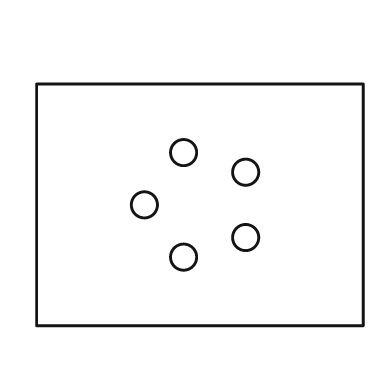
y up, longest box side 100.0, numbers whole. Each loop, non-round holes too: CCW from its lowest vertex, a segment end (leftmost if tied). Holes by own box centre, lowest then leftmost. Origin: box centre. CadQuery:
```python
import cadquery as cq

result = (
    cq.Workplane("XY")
    .moveTo(-50.0, -37.0)
    .lineTo(50.0, -37.0)
    .lineTo(50.0, 37.0)
    .lineTo(-50.0, 37.0)
    .close()
    .moveTo(-5.0, -16.0)
    .circle(4.0)
    .moveTo(14.0, -10.0)
    .circle(4.0)
    .moveTo(-17.0, 0.0)
    .circle(4.0)
    .moveTo(14.0, 10.0)
    .circle(4.0)
    .moveTo(-5.0, 16.0)
    .circle(4.0)
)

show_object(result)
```